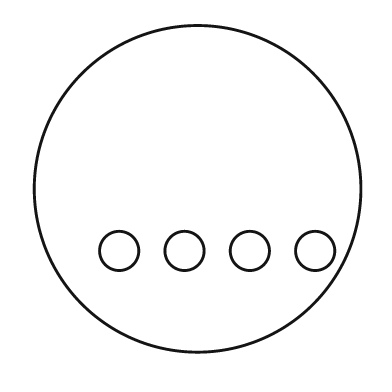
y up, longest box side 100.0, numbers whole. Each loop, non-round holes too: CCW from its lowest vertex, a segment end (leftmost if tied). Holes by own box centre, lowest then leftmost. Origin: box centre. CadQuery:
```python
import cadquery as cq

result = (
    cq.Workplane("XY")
    .moveTo(0.0, 0.0)
    .circle(50.0)
    .moveTo(-24.0, -19.0)
    .circle(6.0)
    .moveTo(-4.0, -19.0)
    .circle(6.0)
    .moveTo(16.0, -19.0)
    .circle(6.0)
    .moveTo(36.0, -19.0)
    .circle(6.0)
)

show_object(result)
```